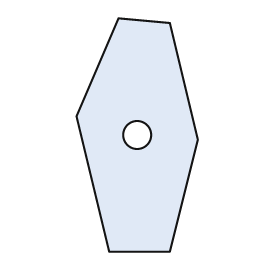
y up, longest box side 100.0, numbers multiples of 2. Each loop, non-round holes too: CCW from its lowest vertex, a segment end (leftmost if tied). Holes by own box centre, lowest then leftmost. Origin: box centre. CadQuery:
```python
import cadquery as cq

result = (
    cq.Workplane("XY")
    .moveTo(-12.0, -50.0)
    .lineTo(14.0, -50.0)
    .lineTo(26.0, -2.0)
    .lineTo(14.0, 48.0)
    .lineTo(-8.0, 50.0)
    .lineTo(-26.0, 8.0)
    .close()
    .moveTo(0.0, 0.0)
    .circle(6.0)
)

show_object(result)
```